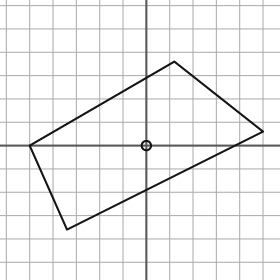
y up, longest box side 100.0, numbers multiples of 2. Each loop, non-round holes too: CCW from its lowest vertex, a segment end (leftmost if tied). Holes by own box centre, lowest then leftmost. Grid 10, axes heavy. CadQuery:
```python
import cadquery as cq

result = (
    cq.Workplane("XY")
    .moveTo(-34.0, -36.0)
    .lineTo(50.0, 6.0)
    .lineTo(12.0, 36.0)
    .lineTo(-50.0, 0.0)
    .close()
    .moveTo(0.0, 0.0)
    .circle(2.0)
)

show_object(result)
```